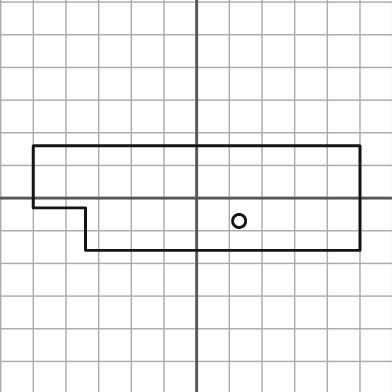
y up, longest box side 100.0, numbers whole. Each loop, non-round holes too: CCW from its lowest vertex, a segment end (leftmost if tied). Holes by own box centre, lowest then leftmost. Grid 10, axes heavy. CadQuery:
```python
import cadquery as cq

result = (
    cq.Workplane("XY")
    .moveTo(-34.0, -16.0)
    .lineTo(50.0, -16.0)
    .lineTo(50.0, 16.0)
    .lineTo(-50.0, 16.0)
    .lineTo(-50.0, -3.0)
    .lineTo(-34.0, -3.0)
    .close()
    .moveTo(13.0, -7.0)
    .circle(2.0)
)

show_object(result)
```